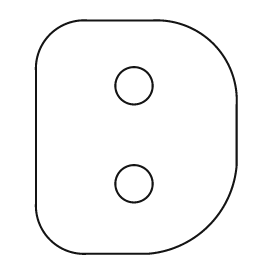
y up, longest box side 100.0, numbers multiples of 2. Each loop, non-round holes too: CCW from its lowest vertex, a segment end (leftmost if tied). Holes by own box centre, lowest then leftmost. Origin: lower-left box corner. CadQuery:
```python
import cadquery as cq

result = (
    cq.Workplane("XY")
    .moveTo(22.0, 0.0)
    .lineTo(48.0, 0.0)
    .threePointArc((74.0, 12.0), (86.0, 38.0))
    .lineTo(86.0, 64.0)
    .threePointArc((76.0, 90.0), (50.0, 100.0))
    .lineTo(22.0, 100.0)
    .threePointArc((6.0, 94.0), (0.0, 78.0))
    .lineTo(0.0, 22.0)
    .threePointArc((6.0, 6.0), (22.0, 0.0))
    .close()
    .moveTo(42.0, 30.0)
    .circle(8.0)
    .moveTo(42.0, 72.0)
    .circle(8.0)
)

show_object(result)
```